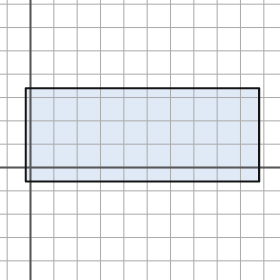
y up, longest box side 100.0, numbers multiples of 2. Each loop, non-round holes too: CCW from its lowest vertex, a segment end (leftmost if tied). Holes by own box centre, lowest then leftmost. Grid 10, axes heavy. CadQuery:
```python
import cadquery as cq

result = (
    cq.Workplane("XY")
    .moveTo(-2.0, -6.0)
    .lineTo(98.0, -6.0)
    .lineTo(98.0, 34.0)
    .lineTo(-2.0, 34.0)
    .close()
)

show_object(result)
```